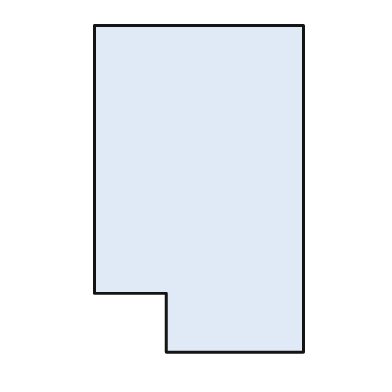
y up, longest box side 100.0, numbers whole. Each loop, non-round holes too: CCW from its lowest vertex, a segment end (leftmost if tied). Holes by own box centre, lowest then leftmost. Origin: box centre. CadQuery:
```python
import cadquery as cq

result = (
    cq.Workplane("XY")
    .moveTo(-10.0, -50.0)
    .lineTo(32.0, -50.0)
    .lineTo(32.0, 50.0)
    .lineTo(-32.0, 50.0)
    .lineTo(-32.0, -32.0)
    .lineTo(-10.0, -32.0)
    .close()
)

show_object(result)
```